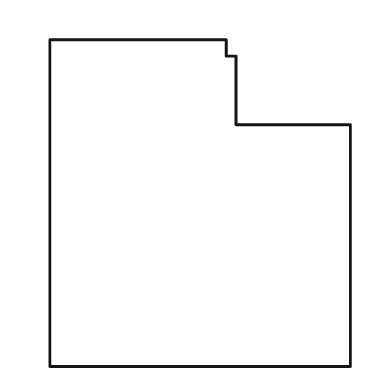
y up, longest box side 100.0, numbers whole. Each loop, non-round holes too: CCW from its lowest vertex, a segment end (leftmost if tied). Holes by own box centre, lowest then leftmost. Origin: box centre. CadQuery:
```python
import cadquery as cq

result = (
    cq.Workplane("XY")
    .moveTo(-46.0, -50.0)
    .lineTo(46.0, -50.0)
    .lineTo(46.0, 24.0)
    .lineTo(11.0, 24.0)
    .lineTo(11.0, 45.0)
    .lineTo(8.0, 45.0)
    .lineTo(8.0, 50.0)
    .lineTo(-46.0, 50.0)
    .close()
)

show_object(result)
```